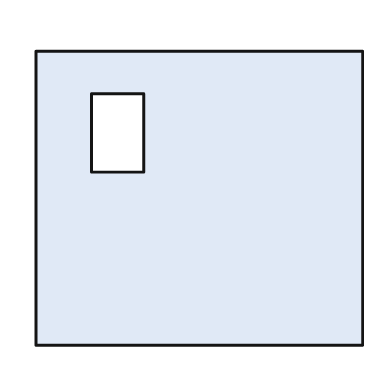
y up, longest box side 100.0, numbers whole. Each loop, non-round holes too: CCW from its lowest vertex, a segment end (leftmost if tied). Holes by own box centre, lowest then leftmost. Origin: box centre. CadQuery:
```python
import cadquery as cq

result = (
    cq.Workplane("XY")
    .moveTo(-50.0, -45.0)
    .lineTo(50.0, -45.0)
    .lineTo(50.0, 45.0)
    .lineTo(-50.0, 45.0)
    .close()
    .moveTo(-33.0, 8.0)
    .lineTo(-17.0, 8.0)
    .lineTo(-17.0, 32.0)
    .lineTo(-33.0, 32.0)
    .close()
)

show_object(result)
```